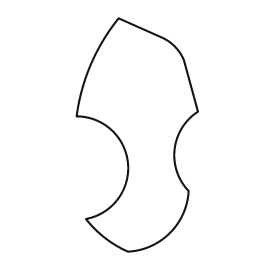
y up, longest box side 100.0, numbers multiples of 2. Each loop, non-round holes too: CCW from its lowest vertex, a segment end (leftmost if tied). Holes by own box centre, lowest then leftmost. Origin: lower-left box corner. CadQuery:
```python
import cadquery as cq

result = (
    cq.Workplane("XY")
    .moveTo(22.0, 0.0)
    .threePointArc((40.0, 8.0), (48.0, 26.0))
    .threePointArc((42.0, 44.0), (52.0, 60.0))
    .lineTo(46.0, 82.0)
    .threePointArc((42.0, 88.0), (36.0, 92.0))
    .lineTo(18.0, 100.0)
    .threePointArc((6.0, 80.0), (0.0, 58.0))
    .threePointArc((22.0, 38.0), (4.0, 14.0))
    .threePointArc((12.0, 6.0), (22.0, 0.0))
    .close()
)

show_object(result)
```